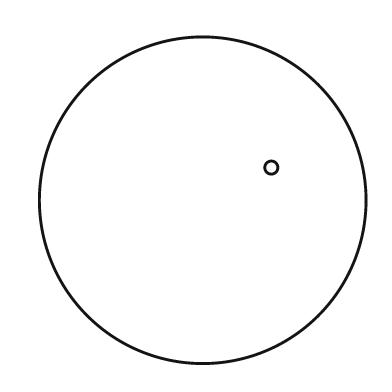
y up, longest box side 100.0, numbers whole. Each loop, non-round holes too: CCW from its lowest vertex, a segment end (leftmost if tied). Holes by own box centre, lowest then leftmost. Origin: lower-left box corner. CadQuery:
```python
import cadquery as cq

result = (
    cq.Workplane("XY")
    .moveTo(50.0, 50.0)
    .circle(50.0)
    .moveTo(71.0, 60.0)
    .circle(2.0)
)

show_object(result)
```